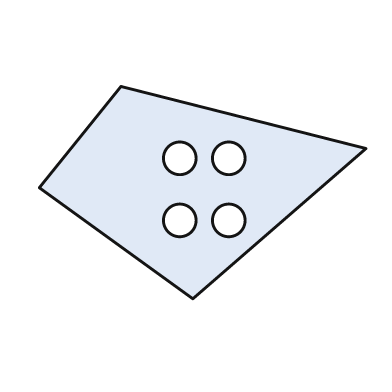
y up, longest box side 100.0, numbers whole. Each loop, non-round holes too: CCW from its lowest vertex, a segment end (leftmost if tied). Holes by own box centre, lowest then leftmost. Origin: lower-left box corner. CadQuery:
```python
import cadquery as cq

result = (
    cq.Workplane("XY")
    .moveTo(47.0, 0.0)
    .lineTo(100.0, 46.0)
    .lineTo(25.0, 65.0)
    .lineTo(0.0, 34.0)
    .close()
    .moveTo(43.0, 24.0)
    .circle(5.0)
    .moveTo(58.0, 24.0)
    .circle(5.0)
    .moveTo(43.0, 43.0)
    .circle(5.0)
    .moveTo(58.0, 43.0)
    .circle(5.0)
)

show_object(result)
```